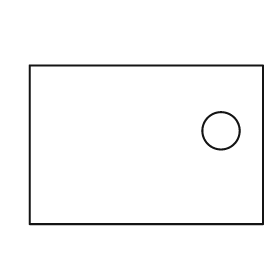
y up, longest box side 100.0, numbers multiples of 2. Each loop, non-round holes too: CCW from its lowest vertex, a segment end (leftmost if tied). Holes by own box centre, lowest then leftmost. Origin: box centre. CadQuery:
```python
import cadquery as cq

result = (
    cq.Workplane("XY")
    .moveTo(-50.0, -34.0)
    .lineTo(50.0, -34.0)
    .lineTo(50.0, 34.0)
    .lineTo(-50.0, 34.0)
    .close()
    .moveTo(32.0, 6.0)
    .circle(8.0)
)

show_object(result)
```